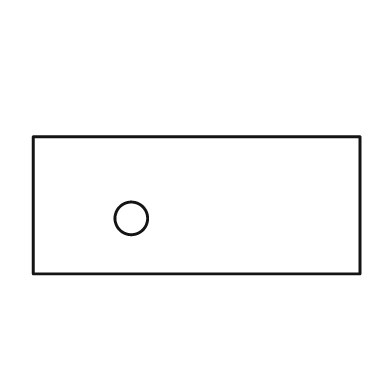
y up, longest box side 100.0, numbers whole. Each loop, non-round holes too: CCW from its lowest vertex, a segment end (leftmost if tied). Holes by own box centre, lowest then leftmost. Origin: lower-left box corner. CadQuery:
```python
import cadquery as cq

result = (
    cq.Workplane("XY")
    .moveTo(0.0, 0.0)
    .lineTo(100.0, 0.0)
    .lineTo(100.0, 42.0)
    .lineTo(0.0, 42.0)
    .close()
    .moveTo(30.0, 17.0)
    .circle(5.0)
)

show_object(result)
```